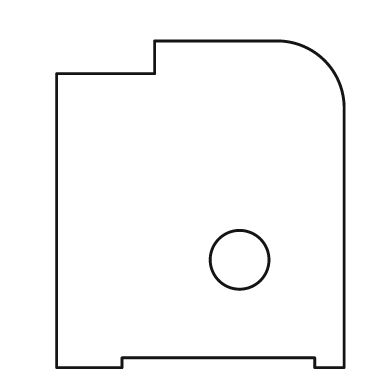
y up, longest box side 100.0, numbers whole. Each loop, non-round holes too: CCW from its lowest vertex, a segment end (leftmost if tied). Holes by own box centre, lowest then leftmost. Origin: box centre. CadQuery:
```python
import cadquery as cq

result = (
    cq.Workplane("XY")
    .moveTo(-44.0, -50.0)
    .lineTo(-24.0, -50.0)
    .lineTo(-24.0, -47.0)
    .lineTo(35.0, -47.0)
    .lineTo(35.0, -50.0)
    .lineTo(44.0, -50.0)
    .lineTo(44.0, 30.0)
    .threePointArc((38.0, 44.0), (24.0, 50.0))
    .lineTo(-14.0, 50.0)
    .lineTo(-14.0, 40.0)
    .lineTo(-44.0, 40.0)
    .close()
    .moveTo(12.0, -17.0)
    .circle(9.0)
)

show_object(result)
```